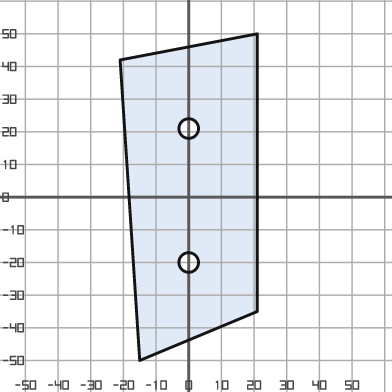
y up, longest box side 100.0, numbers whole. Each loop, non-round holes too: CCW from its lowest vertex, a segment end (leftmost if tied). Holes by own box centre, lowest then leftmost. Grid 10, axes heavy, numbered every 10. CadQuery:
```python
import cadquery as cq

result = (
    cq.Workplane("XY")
    .moveTo(-15.0, -50.0)
    .lineTo(21.0, -35.0)
    .lineTo(21.0, 50.0)
    .lineTo(-21.0, 42.0)
    .close()
    .moveTo(0.0, -20.0)
    .circle(3.0)
    .moveTo(0.0, 21.0)
    .circle(3.0)
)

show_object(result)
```